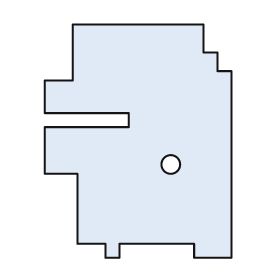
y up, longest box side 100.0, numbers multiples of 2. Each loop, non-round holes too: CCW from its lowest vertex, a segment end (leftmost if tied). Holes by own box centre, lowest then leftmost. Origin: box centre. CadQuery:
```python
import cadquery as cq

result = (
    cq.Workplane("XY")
    .moveTo(-14.0, -50.0)
    .lineTo(-8.0, -50.0)
    .lineTo(-8.0, -44.0)
    .lineTo(24.0, -44.0)
    .lineTo(24.0, -50.0)
    .lineTo(40.0, -50.0)
    .lineTo(40.0, 30.0)
    .lineTo(34.0, 30.0)
    .lineTo(34.0, 38.0)
    .lineTo(28.0, 38.0)
    .lineTo(28.0, 50.0)
    .lineTo(-28.0, 50.0)
    .lineTo(-28.0, 26.0)
    .lineTo(-40.0, 26.0)
    .lineTo(-40.0, 12.0)
    .lineTo(-4.0, 12.0)
    .lineTo(-4.0, 6.0)
    .lineTo(-40.0, 6.0)
    .lineTo(-40.0, -14.0)
    .lineTo(-26.0, -14.0)
    .lineTo(-26.0, -44.0)
    .lineTo(-14.0, -44.0)
    .close()
    .moveTo(14.0, -10.0)
    .circle(4.0)
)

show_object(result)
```